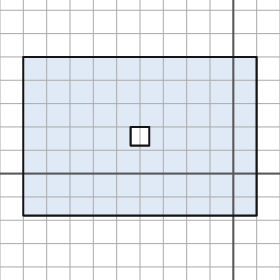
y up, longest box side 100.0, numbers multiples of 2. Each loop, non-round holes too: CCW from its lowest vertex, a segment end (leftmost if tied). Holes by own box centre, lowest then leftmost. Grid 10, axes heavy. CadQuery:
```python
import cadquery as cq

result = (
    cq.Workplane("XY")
    .moveTo(-90.0, -18.0)
    .lineTo(10.0, -18.0)
    .lineTo(10.0, 50.0)
    .lineTo(-90.0, 50.0)
    .close()
    .moveTo(-44.0, 12.0)
    .lineTo(-36.0, 12.0)
    .lineTo(-36.0, 20.0)
    .lineTo(-44.0, 20.0)
    .close()
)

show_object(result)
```